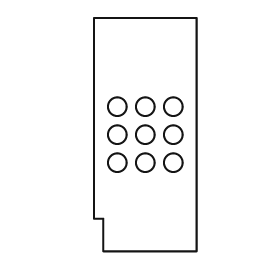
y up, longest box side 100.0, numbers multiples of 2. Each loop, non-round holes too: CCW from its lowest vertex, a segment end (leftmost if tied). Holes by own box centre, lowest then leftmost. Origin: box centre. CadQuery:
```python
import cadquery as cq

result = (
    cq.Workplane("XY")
    .moveTo(-18.0, -50.0)
    .lineTo(22.0, -50.0)
    .lineTo(22.0, 50.0)
    .lineTo(-22.0, 50.0)
    .lineTo(-22.0, -36.0)
    .lineTo(-18.0, -36.0)
    .close()
    .moveTo(-12.0, -12.0)
    .circle(4.0)
    .moveTo(0.0, -12.0)
    .circle(4.0)
    .moveTo(12.0, -12.0)
    .circle(4.0)
    .moveTo(-12.0, 0.0)
    .circle(4.0)
    .moveTo(0.0, 0.0)
    .circle(4.0)
    .moveTo(12.0, 0.0)
    .circle(4.0)
    .moveTo(-12.0, 12.0)
    .circle(4.0)
    .moveTo(0.0, 12.0)
    .circle(4.0)
    .moveTo(12.0, 12.0)
    .circle(4.0)
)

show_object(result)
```